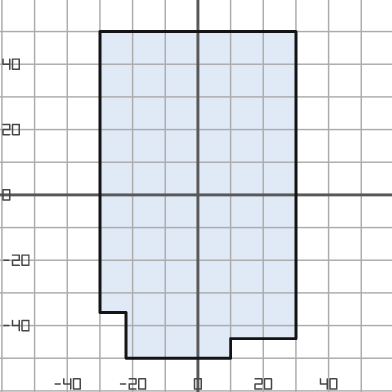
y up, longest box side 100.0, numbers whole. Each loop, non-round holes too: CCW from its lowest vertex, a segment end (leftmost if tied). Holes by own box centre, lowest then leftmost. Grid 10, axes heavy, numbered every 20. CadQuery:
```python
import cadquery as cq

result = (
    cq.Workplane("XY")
    .moveTo(-22.0, -50.0)
    .lineTo(10.0, -50.0)
    .lineTo(10.0, -44.0)
    .lineTo(30.0, -44.0)
    .lineTo(30.0, 50.0)
    .lineTo(-30.0, 50.0)
    .lineTo(-30.0, -36.0)
    .lineTo(-22.0, -36.0)
    .close()
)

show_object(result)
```